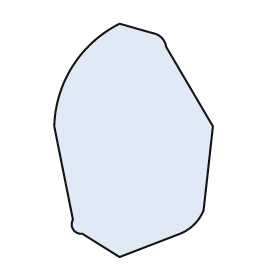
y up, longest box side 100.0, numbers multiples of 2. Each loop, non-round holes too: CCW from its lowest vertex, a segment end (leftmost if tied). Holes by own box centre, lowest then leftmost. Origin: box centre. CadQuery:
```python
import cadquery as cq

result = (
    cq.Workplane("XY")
    .moveTo(-6.0, -50.0)
    .lineTo(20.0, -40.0)
    .threePointArc((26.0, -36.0), (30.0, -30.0))
    .lineTo(34.0, 6.0)
    .lineTo(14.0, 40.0)
    .threePointArc((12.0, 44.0), (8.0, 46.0))
    .lineTo(-6.0, 50.0)
    .threePointArc((-26.0, 32.0), (-34.0, 6.0))
    .lineTo(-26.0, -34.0)
    .threePointArc((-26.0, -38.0), (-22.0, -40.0))
    .close()
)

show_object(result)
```